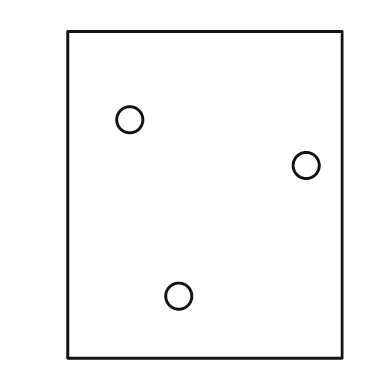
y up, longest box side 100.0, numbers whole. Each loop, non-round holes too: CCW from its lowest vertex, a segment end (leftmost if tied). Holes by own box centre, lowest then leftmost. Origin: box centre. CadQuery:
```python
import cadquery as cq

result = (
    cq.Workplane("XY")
    .moveTo(-42.0, -50.0)
    .lineTo(42.0, -50.0)
    .lineTo(42.0, 50.0)
    .lineTo(-42.0, 50.0)
    .close()
    .moveTo(-8.0, -31.0)
    .circle(4.0)
    .moveTo(31.0, 9.0)
    .circle(4.0)
    .moveTo(-23.0, 23.0)
    .circle(4.0)
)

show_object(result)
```